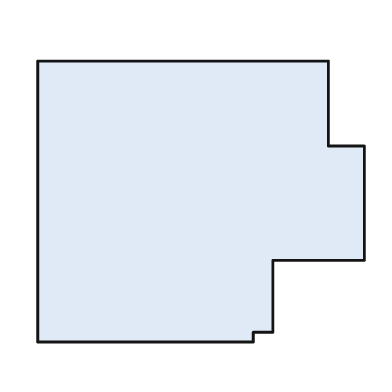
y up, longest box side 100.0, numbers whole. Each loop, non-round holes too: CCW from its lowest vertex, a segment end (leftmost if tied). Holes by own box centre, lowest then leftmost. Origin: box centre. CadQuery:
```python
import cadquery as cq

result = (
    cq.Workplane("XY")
    .moveTo(-50.0, -43.0)
    .lineTo(16.0, -43.0)
    .lineTo(16.0, -40.0)
    .lineTo(22.0, -40.0)
    .lineTo(22.0, -18.0)
    .lineTo(50.0, -18.0)
    .lineTo(50.0, 17.0)
    .lineTo(39.0, 17.0)
    .lineTo(39.0, 43.0)
    .lineTo(-50.0, 43.0)
    .close()
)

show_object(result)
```